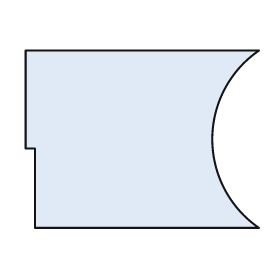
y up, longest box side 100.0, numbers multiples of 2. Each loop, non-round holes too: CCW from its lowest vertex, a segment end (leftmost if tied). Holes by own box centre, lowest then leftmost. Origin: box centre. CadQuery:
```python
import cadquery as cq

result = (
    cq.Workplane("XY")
    .moveTo(-46.0, -38.0)
    .lineTo(50.0, -38.0)
    .threePointArc((30.0, 0.0), (50.0, 38.0))
    .lineTo(-50.0, 38.0)
    .lineTo(-50.0, -4.0)
    .lineTo(-46.0, -4.0)
    .close()
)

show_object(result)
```